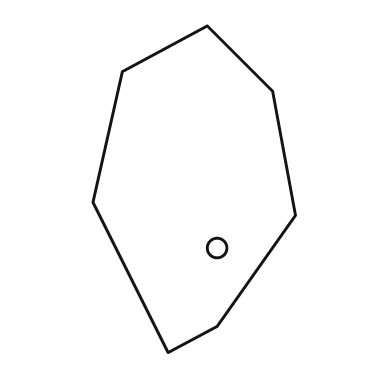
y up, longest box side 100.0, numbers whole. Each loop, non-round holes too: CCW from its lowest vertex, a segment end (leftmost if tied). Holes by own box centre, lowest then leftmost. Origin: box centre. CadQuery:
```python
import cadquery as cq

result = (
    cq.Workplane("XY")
    .moveTo(-8.0, -50.0)
    .lineTo(7.0, -42.0)
    .lineTo(31.0, -8.0)
    .lineTo(24.0, 30.0)
    .lineTo(4.0, 50.0)
    .lineTo(-22.0, 36.0)
    .lineTo(-31.0, -4.0)
    .close()
    .moveTo(7.0, -18.0)
    .circle(3.0)
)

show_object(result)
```